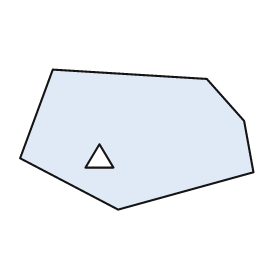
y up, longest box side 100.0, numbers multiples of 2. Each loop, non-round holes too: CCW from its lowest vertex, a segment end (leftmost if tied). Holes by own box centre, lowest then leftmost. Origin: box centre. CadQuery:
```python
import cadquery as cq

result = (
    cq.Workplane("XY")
    .moveTo(-8.0, -30.0)
    .lineTo(50.0, -14.0)
    .lineTo(46.0, 8.0)
    .lineTo(30.0, 26.0)
    .lineTo(-36.0, 30.0)
    .lineTo(-50.0, -8.0)
    .close()
    .moveTo(-22.0, -12.0)
    .lineTo(-10.0, -12.0)
    .lineTo(-16.0, -2.0)
    .close()
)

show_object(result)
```